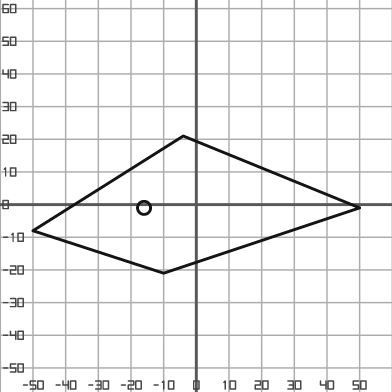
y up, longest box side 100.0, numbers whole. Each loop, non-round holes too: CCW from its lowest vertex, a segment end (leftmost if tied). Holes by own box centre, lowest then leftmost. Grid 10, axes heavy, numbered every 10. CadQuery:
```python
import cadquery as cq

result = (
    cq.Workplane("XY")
    .moveTo(-10.0, -21.0)
    .lineTo(50.0, -1.0)
    .lineTo(-4.0, 21.0)
    .lineTo(-50.0, -8.0)
    .close()
    .moveTo(-16.0, -1.0)
    .circle(2.0)
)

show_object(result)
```